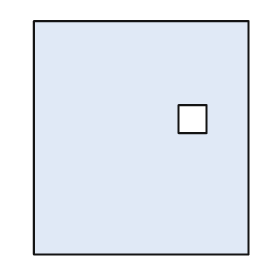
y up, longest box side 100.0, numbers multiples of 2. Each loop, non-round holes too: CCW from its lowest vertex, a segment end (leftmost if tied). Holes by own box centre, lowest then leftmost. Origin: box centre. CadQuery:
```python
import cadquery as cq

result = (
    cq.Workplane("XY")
    .moveTo(-46.0, -50.0)
    .lineTo(46.0, -50.0)
    .lineTo(46.0, 50.0)
    .lineTo(-46.0, 50.0)
    .close()
    .moveTo(16.0, 2.0)
    .lineTo(28.0, 2.0)
    .lineTo(28.0, 14.0)
    .lineTo(16.0, 14.0)
    .close()
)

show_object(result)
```